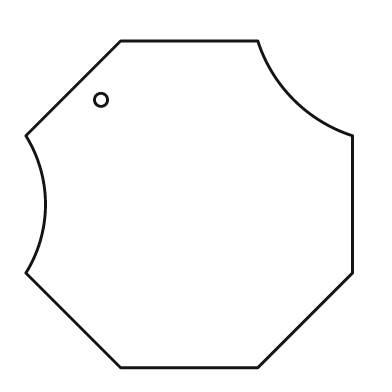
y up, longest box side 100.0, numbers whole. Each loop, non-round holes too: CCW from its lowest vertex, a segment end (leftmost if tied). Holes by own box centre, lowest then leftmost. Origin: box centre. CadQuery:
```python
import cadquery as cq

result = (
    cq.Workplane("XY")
    .moveTo(-21.0, -50.0)
    .lineTo(21.0, -50.0)
    .lineTo(50.0, -21.0)
    .lineTo(50.0, 21.0)
    .threePointArc((32.0, 32.0), (21.0, 50.0))
    .lineTo(-21.0, 50.0)
    .lineTo(-50.0, 21.0)
    .threePointArc((-44.0, 0.0), (-50.0, -21.0))
    .close()
    .moveTo(-27.0, 32.0)
    .circle(2.0)
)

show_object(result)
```